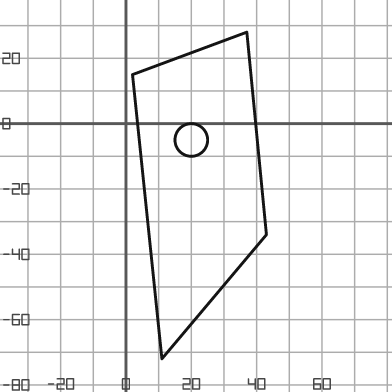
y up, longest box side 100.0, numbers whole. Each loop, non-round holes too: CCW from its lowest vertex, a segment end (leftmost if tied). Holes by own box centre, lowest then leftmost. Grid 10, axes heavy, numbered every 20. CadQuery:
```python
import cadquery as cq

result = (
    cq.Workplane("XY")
    .moveTo(11.0, -72.0)
    .lineTo(43.0, -34.0)
    .lineTo(37.0, 28.0)
    .lineTo(2.0, 15.0)
    .close()
    .moveTo(20.0, -5.0)
    .circle(5.0)
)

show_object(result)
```